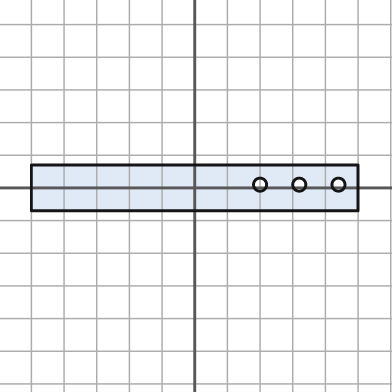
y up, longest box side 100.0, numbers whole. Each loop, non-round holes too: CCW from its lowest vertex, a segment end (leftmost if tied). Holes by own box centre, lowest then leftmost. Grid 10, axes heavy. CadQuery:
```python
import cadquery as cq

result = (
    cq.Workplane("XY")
    .moveTo(-50.0, -7.0)
    .lineTo(50.0, -7.0)
    .lineTo(50.0, 7.0)
    .lineTo(-50.0, 7.0)
    .close()
    .moveTo(20.0, 1.0)
    .circle(2.0)
    .moveTo(32.0, 1.0)
    .circle(2.0)
    .moveTo(44.0, 1.0)
    .circle(2.0)
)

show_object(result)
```